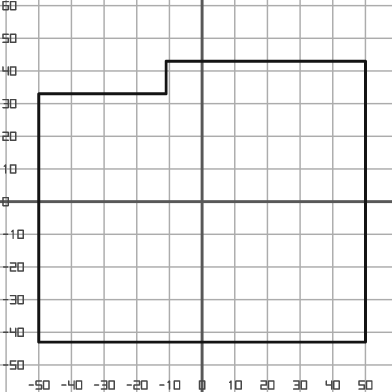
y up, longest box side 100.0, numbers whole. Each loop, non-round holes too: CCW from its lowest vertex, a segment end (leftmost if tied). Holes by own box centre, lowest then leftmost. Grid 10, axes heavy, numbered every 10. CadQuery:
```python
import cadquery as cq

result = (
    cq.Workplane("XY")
    .moveTo(-50.0, -43.0)
    .lineTo(50.0, -43.0)
    .lineTo(50.0, 43.0)
    .lineTo(-11.0, 43.0)
    .lineTo(-11.0, 33.0)
    .lineTo(-50.0, 33.0)
    .close()
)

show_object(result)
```